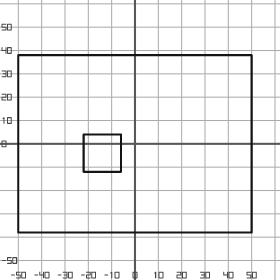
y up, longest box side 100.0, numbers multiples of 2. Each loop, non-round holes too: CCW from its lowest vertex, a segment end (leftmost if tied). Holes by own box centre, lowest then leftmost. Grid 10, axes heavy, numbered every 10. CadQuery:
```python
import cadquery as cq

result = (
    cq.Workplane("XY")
    .moveTo(-50.0, -38.0)
    .lineTo(50.0, -38.0)
    .lineTo(50.0, 38.0)
    .lineTo(-50.0, 38.0)
    .close()
    .moveTo(-22.0, -12.0)
    .lineTo(-6.0, -12.0)
    .lineTo(-6.0, 4.0)
    .lineTo(-22.0, 4.0)
    .close()
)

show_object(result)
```